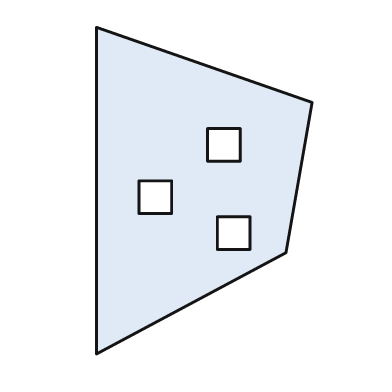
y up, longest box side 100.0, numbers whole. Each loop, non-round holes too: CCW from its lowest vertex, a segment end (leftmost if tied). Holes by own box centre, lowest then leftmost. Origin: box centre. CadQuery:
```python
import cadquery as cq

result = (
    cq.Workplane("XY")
    .moveTo(-33.0, -50.0)
    .lineTo(25.0, -19.0)
    .lineTo(33.0, 27.0)
    .lineTo(-33.0, 50.0)
    .close()
    .moveTo(4.0, -18.0)
    .lineTo(14.0, -18.0)
    .lineTo(14.0, -8.0)
    .lineTo(4.0, -8.0)
    .close()
    .moveTo(-20.0, -7.0)
    .lineTo(-10.0, -7.0)
    .lineTo(-10.0, 3.0)
    .lineTo(-20.0, 3.0)
    .close()
    .moveTo(1.0, 9.0)
    .lineTo(11.0, 9.0)
    .lineTo(11.0, 19.0)
    .lineTo(1.0, 19.0)
    .close()
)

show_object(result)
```